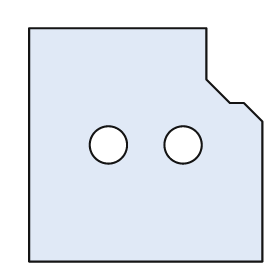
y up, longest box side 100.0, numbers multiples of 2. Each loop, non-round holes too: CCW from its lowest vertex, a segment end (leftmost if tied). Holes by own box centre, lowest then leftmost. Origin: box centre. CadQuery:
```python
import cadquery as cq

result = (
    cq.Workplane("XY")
    .moveTo(-50.0, -50.0)
    .lineTo(50.0, -50.0)
    .lineTo(50.0, 10.0)
    .lineTo(42.0, 18.0)
    .lineTo(36.0, 18.0)
    .lineTo(26.0, 28.0)
    .lineTo(26.0, 50.0)
    .lineTo(-50.0, 50.0)
    .close()
    .moveTo(-16.0, 0.0)
    .circle(8.0)
    .moveTo(16.0, 0.0)
    .circle(8.0)
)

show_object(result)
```